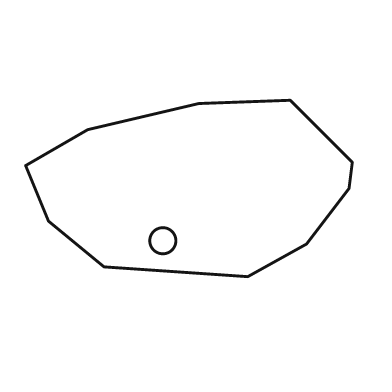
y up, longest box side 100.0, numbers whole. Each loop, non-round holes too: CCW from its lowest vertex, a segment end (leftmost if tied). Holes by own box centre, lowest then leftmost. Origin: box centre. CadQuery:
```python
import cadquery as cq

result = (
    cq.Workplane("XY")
    .moveTo(18.0, -27.0)
    .lineTo(36.0, -17.0)
    .lineTo(49.0, 0.0)
    .lineTo(50.0, 8.0)
    .lineTo(31.0, 27.0)
    .lineTo(3.0, 26.0)
    .lineTo(-31.0, 18.0)
    .lineTo(-50.0, 7.0)
    .lineTo(-43.0, -10.0)
    .lineTo(-26.0, -24.0)
    .close()
    .moveTo(-8.0, -16.0)
    .circle(4.0)
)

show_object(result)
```